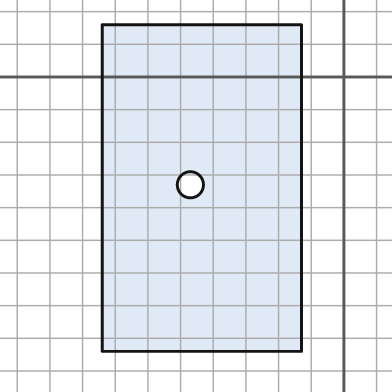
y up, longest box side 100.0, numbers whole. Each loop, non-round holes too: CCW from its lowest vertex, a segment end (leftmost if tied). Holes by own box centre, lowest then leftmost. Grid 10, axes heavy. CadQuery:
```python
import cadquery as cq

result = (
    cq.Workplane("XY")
    .moveTo(-74.0, -84.0)
    .lineTo(-13.0, -84.0)
    .lineTo(-13.0, 16.0)
    .lineTo(-74.0, 16.0)
    .close()
    .moveTo(-47.0, -33.0)
    .circle(4.0)
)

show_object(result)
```